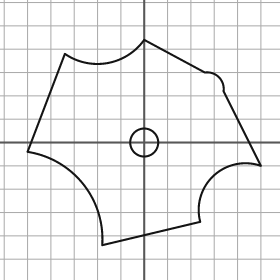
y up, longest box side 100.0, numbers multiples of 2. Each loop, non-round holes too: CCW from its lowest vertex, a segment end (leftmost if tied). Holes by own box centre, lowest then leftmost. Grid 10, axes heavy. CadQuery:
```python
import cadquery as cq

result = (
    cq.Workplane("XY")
    .moveTo(-18.0, -44.0)
    .lineTo(24.0, -34.0)
    .threePointArc((30.0, -14.0), (50.0, -10.0))
    .lineTo(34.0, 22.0)
    .threePointArc((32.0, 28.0), (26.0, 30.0))
    .lineTo(0.0, 44.0)
    .threePointArc((-16.0, 34.0), (-34.0, 38.0))
    .lineTo(-50.0, -4.0)
    .threePointArc((-26.0, -18.0), (-18.0, -44.0))
    .close()
    .moveTo(0.0, 0.0)
    .circle(6.0)
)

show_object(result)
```